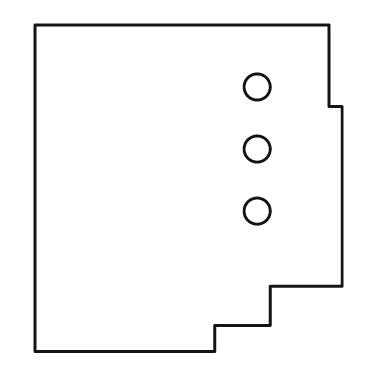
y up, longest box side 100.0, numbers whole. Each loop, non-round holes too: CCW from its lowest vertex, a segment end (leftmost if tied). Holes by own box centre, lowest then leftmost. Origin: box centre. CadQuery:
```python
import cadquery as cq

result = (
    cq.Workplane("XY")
    .moveTo(-47.0, -50.0)
    .lineTo(8.0, -50.0)
    .lineTo(8.0, -42.0)
    .lineTo(25.0, -42.0)
    .lineTo(25.0, -30.0)
    .lineTo(47.0, -30.0)
    .lineTo(47.0, 25.0)
    .lineTo(43.0, 25.0)
    .lineTo(43.0, 50.0)
    .lineTo(-47.0, 50.0)
    .close()
    .moveTo(21.0, -7.0)
    .circle(4.0)
    .moveTo(21.0, 12.0)
    .circle(4.0)
    .moveTo(21.0, 31.0)
    .circle(4.0)
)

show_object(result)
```